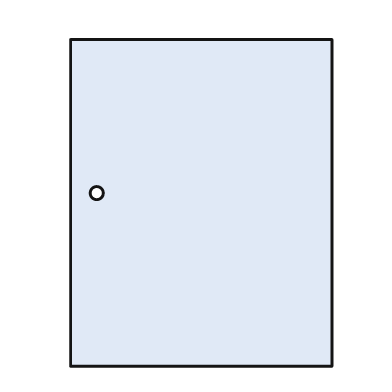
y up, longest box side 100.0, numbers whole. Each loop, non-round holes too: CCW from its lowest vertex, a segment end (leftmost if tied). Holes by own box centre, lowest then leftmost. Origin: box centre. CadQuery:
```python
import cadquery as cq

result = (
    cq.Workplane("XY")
    .moveTo(-40.0, -50.0)
    .lineTo(40.0, -50.0)
    .lineTo(40.0, 50.0)
    .lineTo(-40.0, 50.0)
    .close()
    .moveTo(-32.0, 3.0)
    .circle(2.0)
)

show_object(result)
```